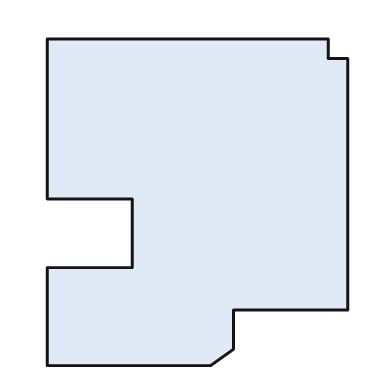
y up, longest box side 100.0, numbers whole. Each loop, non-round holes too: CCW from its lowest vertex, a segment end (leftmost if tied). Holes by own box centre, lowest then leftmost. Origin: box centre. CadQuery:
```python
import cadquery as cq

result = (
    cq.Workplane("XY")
    .moveTo(-46.0, -50.0)
    .lineTo(4.0, -50.0)
    .lineTo(11.0, -45.0)
    .lineTo(11.0, -33.0)
    .lineTo(46.0, -33.0)
    .lineTo(46.0, 44.0)
    .lineTo(40.0, 44.0)
    .lineTo(40.0, 50.0)
    .lineTo(-46.0, 50.0)
    .lineTo(-46.0, 1.0)
    .lineTo(-20.0, 1.0)
    .lineTo(-20.0, -20.0)
    .lineTo(-46.0, -20.0)
    .close()
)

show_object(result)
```